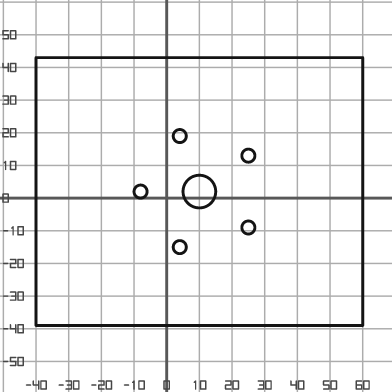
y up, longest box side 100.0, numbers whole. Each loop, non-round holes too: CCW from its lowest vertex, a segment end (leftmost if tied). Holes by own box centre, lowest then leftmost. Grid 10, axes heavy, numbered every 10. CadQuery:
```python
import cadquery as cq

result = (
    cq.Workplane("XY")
    .moveTo(-40.0, -39.0)
    .lineTo(60.0, -39.0)
    .lineTo(60.0, 43.0)
    .lineTo(-40.0, 43.0)
    .close()
    .moveTo(4.0, -15.0)
    .circle(2.0)
    .moveTo(25.0, -9.0)
    .circle(2.0)
    .moveTo(-8.0, 2.0)
    .circle(2.0)
    .moveTo(10.0, 2.0)
    .circle(5.0)
    .moveTo(25.0, 13.0)
    .circle(2.0)
    .moveTo(4.0, 19.0)
    .circle(2.0)
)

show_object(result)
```